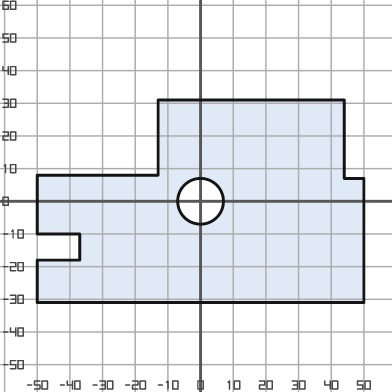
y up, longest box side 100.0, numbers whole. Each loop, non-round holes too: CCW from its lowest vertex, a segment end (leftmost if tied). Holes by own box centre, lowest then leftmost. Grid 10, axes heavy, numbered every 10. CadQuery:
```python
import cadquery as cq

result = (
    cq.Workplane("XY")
    .moveTo(-50.0, -31.0)
    .lineTo(50.0, -31.0)
    .lineTo(50.0, 7.0)
    .lineTo(44.0, 7.0)
    .lineTo(44.0, 31.0)
    .lineTo(-13.0, 31.0)
    .lineTo(-13.0, 8.0)
    .lineTo(-50.0, 8.0)
    .lineTo(-50.0, -10.0)
    .lineTo(-37.0, -10.0)
    .lineTo(-37.0, -18.0)
    .lineTo(-50.0, -18.0)
    .close()
    .moveTo(0.0, 0.0)
    .circle(7.0)
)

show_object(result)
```